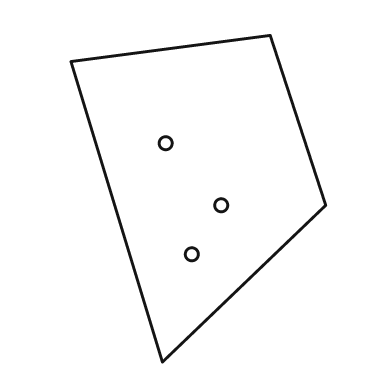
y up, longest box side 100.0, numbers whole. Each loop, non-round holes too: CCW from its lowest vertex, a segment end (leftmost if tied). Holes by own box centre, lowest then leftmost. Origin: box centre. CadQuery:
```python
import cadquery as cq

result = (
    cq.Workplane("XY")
    .moveTo(-11.0, -50.0)
    .lineTo(39.0, -2.0)
    .lineTo(22.0, 50.0)
    .lineTo(-39.0, 42.0)
    .close()
    .moveTo(-2.0, -17.0)
    .circle(2.0)
    .moveTo(7.0, -2.0)
    .circle(2.0)
    .moveTo(-10.0, 17.0)
    .circle(2.0)
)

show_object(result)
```